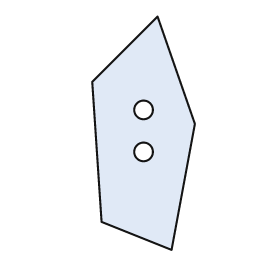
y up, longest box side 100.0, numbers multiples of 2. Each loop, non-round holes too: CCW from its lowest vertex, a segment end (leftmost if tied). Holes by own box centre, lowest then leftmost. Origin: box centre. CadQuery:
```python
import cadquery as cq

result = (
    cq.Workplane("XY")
    .moveTo(12.0, -50.0)
    .lineTo(22.0, 4.0)
    .lineTo(6.0, 50.0)
    .lineTo(-22.0, 22.0)
    .lineTo(-18.0, -38.0)
    .close()
    .moveTo(0.0, -8.0)
    .circle(4.0)
    .moveTo(0.0, 10.0)
    .circle(4.0)
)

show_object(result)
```